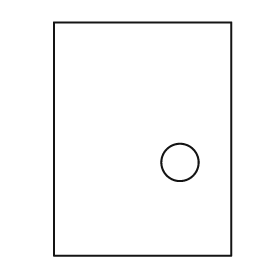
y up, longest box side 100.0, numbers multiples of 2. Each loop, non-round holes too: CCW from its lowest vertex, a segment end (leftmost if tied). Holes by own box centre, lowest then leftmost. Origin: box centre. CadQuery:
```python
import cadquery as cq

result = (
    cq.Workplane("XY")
    .moveTo(-38.0, -50.0)
    .lineTo(38.0, -50.0)
    .lineTo(38.0, 50.0)
    .lineTo(-38.0, 50.0)
    .close()
    .moveTo(16.0, -10.0)
    .circle(8.0)
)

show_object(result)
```